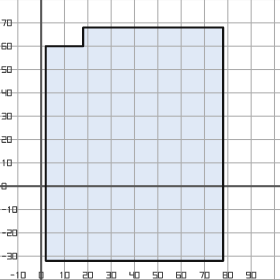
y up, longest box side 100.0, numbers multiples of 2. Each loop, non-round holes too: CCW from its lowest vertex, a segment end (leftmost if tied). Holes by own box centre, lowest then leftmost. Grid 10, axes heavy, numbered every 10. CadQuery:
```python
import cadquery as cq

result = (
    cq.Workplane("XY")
    .moveTo(2.0, -32.0)
    .lineTo(78.0, -32.0)
    .lineTo(78.0, 68.0)
    .lineTo(18.0, 68.0)
    .lineTo(18.0, 60.0)
    .lineTo(2.0, 60.0)
    .close()
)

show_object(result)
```